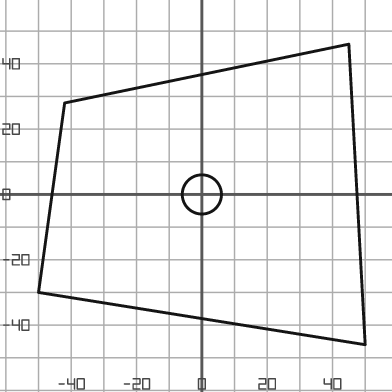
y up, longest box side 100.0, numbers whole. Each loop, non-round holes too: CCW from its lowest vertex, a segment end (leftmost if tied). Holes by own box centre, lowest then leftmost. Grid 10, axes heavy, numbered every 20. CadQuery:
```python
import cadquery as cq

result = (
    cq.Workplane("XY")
    .moveTo(50.0, -46.0)
    .lineTo(45.0, 46.0)
    .lineTo(-42.0, 28.0)
    .lineTo(-50.0, -30.0)
    .close()
    .moveTo(0.0, 0.0)
    .circle(6.0)
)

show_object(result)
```